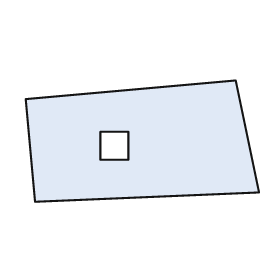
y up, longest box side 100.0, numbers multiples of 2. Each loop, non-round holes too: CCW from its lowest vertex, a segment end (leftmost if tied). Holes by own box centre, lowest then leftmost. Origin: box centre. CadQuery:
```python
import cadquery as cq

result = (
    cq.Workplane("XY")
    .moveTo(-46.0, -26.0)
    .lineTo(50.0, -22.0)
    .lineTo(40.0, 26.0)
    .lineTo(-50.0, 18.0)
    .close()
    .moveTo(-18.0, -8.0)
    .lineTo(-6.0, -8.0)
    .lineTo(-6.0, 4.0)
    .lineTo(-18.0, 4.0)
    .close()
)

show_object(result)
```